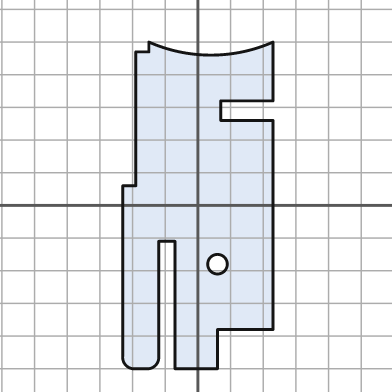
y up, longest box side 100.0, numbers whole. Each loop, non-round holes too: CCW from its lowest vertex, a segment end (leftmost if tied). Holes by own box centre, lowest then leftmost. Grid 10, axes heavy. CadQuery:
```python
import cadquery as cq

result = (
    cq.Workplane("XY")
    .moveTo(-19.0, -50.0)
    .lineTo(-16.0, -50.0)
    .threePointArc((-13.0, -49.0), (-12.0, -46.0))
    .lineTo(-12.0, -11.0)
    .lineTo(-7.0, -11.0)
    .lineTo(-7.0, -50.0)
    .lineTo(6.0, -50.0)
    .lineTo(6.0, -38.0)
    .lineTo(23.0, -38.0)
    .lineTo(23.0, 26.0)
    .lineTo(7.0, 26.0)
    .lineTo(7.0, 32.0)
    .lineTo(23.0, 32.0)
    .lineTo(23.0, 50.0)
    .threePointArc((4.0, 46.0), (-15.0, 50.0))
    .lineTo(-15.0, 47.0)
    .lineTo(-19.0, 47.0)
    .lineTo(-19.0, 6.0)
    .lineTo(-23.0, 6.0)
    .lineTo(-23.0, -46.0)
    .threePointArc((-22.0, -49.0), (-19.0, -50.0))
    .close()
    .moveTo(6.0, -18.0)
    .circle(3.0)
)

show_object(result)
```